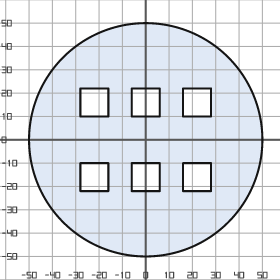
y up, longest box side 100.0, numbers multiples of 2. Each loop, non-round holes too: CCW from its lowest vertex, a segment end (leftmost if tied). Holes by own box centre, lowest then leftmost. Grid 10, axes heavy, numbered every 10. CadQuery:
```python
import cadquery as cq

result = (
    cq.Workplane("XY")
    .moveTo(0.0, 0.0)
    .circle(50.0)
    .moveTo(-28.0, -22.0)
    .lineTo(-16.0, -22.0)
    .lineTo(-16.0, -10.0)
    .lineTo(-28.0, -10.0)
    .close()
    .moveTo(-6.0, -22.0)
    .lineTo(6.0, -22.0)
    .lineTo(6.0, -10.0)
    .lineTo(-6.0, -10.0)
    .close()
    .moveTo(16.0, -22.0)
    .lineTo(28.0, -22.0)
    .lineTo(28.0, -10.0)
    .lineTo(16.0, -10.0)
    .close()
    .moveTo(-28.0, 10.0)
    .lineTo(-16.0, 10.0)
    .lineTo(-16.0, 22.0)
    .lineTo(-28.0, 22.0)
    .close()
    .moveTo(-6.0, 10.0)
    .lineTo(6.0, 10.0)
    .lineTo(6.0, 22.0)
    .lineTo(-6.0, 22.0)
    .close()
    .moveTo(16.0, 10.0)
    .lineTo(28.0, 10.0)
    .lineTo(28.0, 22.0)
    .lineTo(16.0, 22.0)
    .close()
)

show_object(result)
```